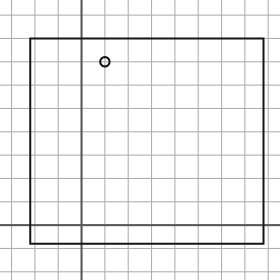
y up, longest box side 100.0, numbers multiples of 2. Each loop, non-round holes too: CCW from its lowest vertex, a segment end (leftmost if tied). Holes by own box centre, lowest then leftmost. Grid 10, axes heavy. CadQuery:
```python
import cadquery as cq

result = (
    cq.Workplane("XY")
    .moveTo(-22.0, -8.0)
    .lineTo(78.0, -8.0)
    .lineTo(78.0, 80.0)
    .lineTo(-22.0, 80.0)
    .close()
    .moveTo(10.0, 70.0)
    .circle(2.0)
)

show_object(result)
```